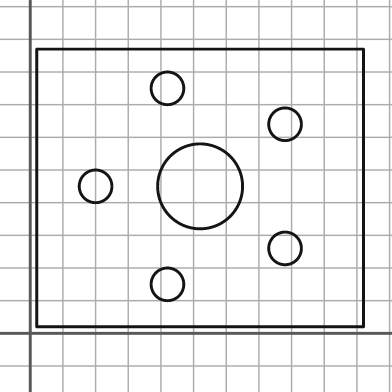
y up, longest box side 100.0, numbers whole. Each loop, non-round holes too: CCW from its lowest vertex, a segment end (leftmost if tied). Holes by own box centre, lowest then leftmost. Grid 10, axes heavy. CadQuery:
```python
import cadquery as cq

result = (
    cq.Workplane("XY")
    .moveTo(2.0, 2.0)
    .lineTo(102.0, 2.0)
    .lineTo(102.0, 87.0)
    .lineTo(2.0, 87.0)
    .close()
    .moveTo(42.0, 15.0)
    .circle(5.0)
    .moveTo(78.0, 26.0)
    .circle(5.0)
    .moveTo(20.0, 45.0)
    .circle(5.0)
    .moveTo(52.0, 45.0)
    .circle(13.0)
    .moveTo(78.0, 64.0)
    .circle(5.0)
    .moveTo(42.0, 75.0)
    .circle(5.0)
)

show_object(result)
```